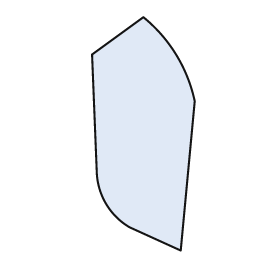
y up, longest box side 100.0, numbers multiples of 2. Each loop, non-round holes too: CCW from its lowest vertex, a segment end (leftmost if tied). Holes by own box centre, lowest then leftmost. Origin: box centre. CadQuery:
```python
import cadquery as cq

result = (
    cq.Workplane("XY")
    .moveTo(16.0, -50.0)
    .lineTo(22.0, 14.0)
    .threePointArc((14.0, 34.0), (0.0, 50.0))
    .lineTo(-22.0, 34.0)
    .lineTo(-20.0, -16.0)
    .threePointArc((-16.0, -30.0), (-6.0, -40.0))
    .close()
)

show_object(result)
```